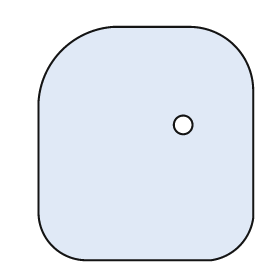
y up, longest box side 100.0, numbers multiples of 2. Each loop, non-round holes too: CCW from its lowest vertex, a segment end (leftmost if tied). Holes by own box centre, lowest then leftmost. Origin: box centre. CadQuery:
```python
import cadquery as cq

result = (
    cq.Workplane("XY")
    .moveTo(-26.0, -50.0)
    .lineTo(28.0, -50.0)
    .threePointArc((40.0, -44.0), (46.0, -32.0))
    .lineTo(46.0, 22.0)
    .threePointArc((38.0, 42.0), (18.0, 50.0))
    .lineTo(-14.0, 50.0)
    .threePointArc((-36.0, 40.0), (-46.0, 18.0))
    .lineTo(-46.0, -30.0)
    .threePointArc((-40.0, -44.0), (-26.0, -50.0))
    .close()
    .moveTo(16.0, 8.0)
    .circle(4.0)
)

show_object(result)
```